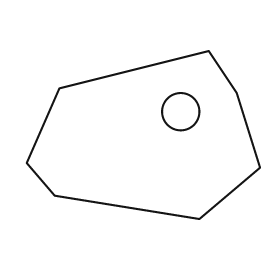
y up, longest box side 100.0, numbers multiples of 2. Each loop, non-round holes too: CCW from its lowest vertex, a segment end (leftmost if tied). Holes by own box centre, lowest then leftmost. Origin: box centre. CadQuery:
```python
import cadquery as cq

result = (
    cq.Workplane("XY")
    .moveTo(24.0, -36.0)
    .lineTo(50.0, -14.0)
    .lineTo(40.0, 18.0)
    .lineTo(28.0, 36.0)
    .lineTo(-36.0, 20.0)
    .lineTo(-50.0, -12.0)
    .lineTo(-38.0, -26.0)
    .close()
    .moveTo(16.0, 10.0)
    .circle(8.0)
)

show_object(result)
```